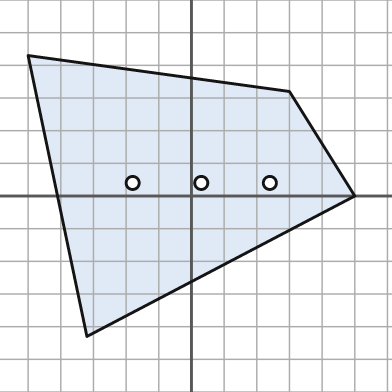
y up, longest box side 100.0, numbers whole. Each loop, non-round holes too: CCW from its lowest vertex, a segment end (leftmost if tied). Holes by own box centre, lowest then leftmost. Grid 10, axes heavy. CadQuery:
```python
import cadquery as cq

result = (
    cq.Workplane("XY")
    .moveTo(-32.0, -43.0)
    .lineTo(50.0, 0.0)
    .lineTo(30.0, 32.0)
    .lineTo(-50.0, 43.0)
    .close()
    .moveTo(-18.0, 4.0)
    .circle(2.0)
    .moveTo(3.0, 4.0)
    .circle(2.0)
    .moveTo(24.0, 4.0)
    .circle(2.0)
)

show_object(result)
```